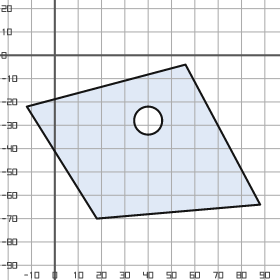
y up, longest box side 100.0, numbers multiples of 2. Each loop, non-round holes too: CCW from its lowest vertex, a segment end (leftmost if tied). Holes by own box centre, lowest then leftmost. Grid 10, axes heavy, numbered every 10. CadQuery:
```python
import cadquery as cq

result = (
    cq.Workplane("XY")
    .moveTo(18.0, -70.0)
    .lineTo(88.0, -64.0)
    .lineTo(56.0, -4.0)
    .lineTo(-12.0, -22.0)
    .close()
    .moveTo(40.0, -28.0)
    .circle(6.0)
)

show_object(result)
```